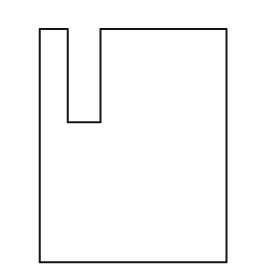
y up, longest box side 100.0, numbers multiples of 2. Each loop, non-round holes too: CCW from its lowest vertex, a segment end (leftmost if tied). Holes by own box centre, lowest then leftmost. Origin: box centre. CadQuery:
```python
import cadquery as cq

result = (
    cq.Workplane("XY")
    .moveTo(-40.0, -50.0)
    .lineTo(40.0, -50.0)
    .lineTo(40.0, 50.0)
    .lineTo(-14.0, 50.0)
    .lineTo(-14.0, 10.0)
    .lineTo(-28.0, 10.0)
    .lineTo(-28.0, 50.0)
    .lineTo(-40.0, 50.0)
    .close()
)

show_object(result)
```